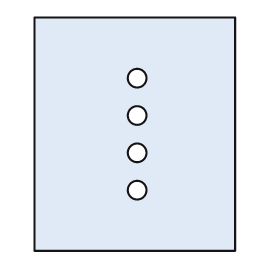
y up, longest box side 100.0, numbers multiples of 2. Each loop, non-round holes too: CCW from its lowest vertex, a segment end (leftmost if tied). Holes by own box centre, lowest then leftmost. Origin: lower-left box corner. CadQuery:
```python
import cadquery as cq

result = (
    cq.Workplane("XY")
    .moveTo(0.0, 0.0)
    .lineTo(86.0, 0.0)
    .lineTo(86.0, 100.0)
    .lineTo(0.0, 100.0)
    .close()
    .moveTo(44.0, 26.0)
    .circle(4.0)
    .moveTo(44.0, 42.0)
    .circle(4.0)
    .moveTo(44.0, 58.0)
    .circle(4.0)
    .moveTo(44.0, 74.0)
    .circle(4.0)
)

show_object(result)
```